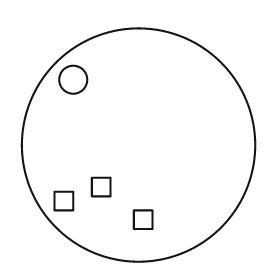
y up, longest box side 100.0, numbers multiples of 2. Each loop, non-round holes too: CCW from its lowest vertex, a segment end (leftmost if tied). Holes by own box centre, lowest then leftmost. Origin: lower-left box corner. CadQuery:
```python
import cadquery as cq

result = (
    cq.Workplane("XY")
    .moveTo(50.0, 50.0)
    .circle(50.0)
    .moveTo(48.0, 14.0)
    .lineTo(56.0, 14.0)
    .lineTo(56.0, 22.0)
    .lineTo(48.0, 22.0)
    .close()
    .moveTo(14.0, 22.0)
    .lineTo(22.0, 22.0)
    .lineTo(22.0, 30.0)
    .lineTo(14.0, 30.0)
    .close()
    .moveTo(30.0, 28.0)
    .lineTo(38.0, 28.0)
    .lineTo(38.0, 36.0)
    .lineTo(30.0, 36.0)
    .close()
    .moveTo(22.0, 78.0)
    .circle(6.0)
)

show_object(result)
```